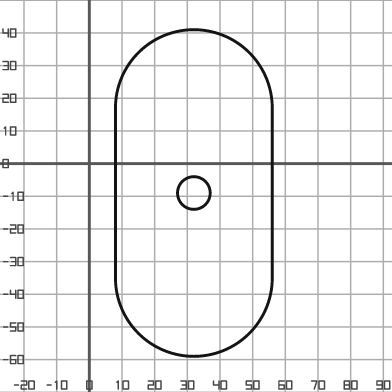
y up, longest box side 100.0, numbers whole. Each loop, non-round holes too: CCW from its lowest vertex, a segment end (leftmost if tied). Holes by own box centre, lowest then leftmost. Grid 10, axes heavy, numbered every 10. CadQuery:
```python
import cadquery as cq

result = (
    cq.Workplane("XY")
    .moveTo(8.0, -35.0)
    .threePointArc((32.0, -59.0), (56.0, -35.0))
    .lineTo(56.0, 17.0)
    .threePointArc((32.0, 41.0), (8.0, 17.0))
    .close()
    .moveTo(32.0, -9.0)
    .circle(5.0)
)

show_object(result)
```